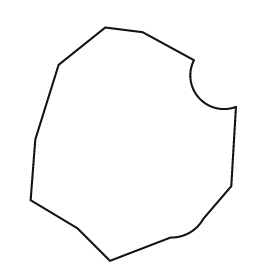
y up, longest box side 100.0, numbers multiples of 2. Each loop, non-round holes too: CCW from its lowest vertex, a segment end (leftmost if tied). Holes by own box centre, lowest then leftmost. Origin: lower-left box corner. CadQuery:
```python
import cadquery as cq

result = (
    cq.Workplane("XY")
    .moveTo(34.0, 0.0)
    .lineTo(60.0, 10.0)
    .threePointArc((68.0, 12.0), (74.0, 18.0))
    .lineTo(86.0, 32.0)
    .lineTo(88.0, 66.0)
    .threePointArc((72.0, 70.0), (70.0, 86.0))
    .lineTo(48.0, 98.0)
    .lineTo(32.0, 100.0)
    .lineTo(12.0, 84.0)
    .lineTo(2.0, 52.0)
    .lineTo(0.0, 26.0)
    .lineTo(20.0, 14.0)
    .close()
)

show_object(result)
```